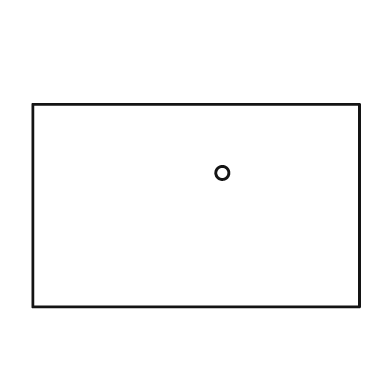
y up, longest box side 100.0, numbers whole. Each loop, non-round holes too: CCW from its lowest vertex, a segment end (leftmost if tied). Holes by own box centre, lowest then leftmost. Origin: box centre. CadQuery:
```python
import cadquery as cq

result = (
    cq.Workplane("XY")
    .moveTo(-50.0, -31.0)
    .lineTo(50.0, -31.0)
    .lineTo(50.0, 31.0)
    .lineTo(-50.0, 31.0)
    .close()
    .moveTo(8.0, 10.0)
    .circle(2.0)
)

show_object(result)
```